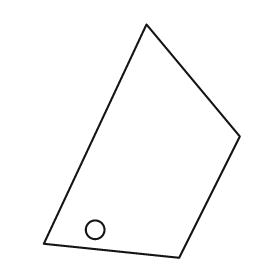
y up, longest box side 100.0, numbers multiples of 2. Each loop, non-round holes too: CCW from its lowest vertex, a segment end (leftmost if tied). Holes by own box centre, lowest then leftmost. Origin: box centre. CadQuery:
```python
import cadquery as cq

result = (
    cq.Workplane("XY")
    .moveTo(16.0, -50.0)
    .lineTo(42.0, 2.0)
    .lineTo(2.0, 50.0)
    .lineTo(-42.0, -44.0)
    .close()
    .moveTo(-20.0, -38.0)
    .circle(4.0)
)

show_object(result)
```